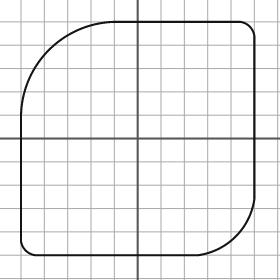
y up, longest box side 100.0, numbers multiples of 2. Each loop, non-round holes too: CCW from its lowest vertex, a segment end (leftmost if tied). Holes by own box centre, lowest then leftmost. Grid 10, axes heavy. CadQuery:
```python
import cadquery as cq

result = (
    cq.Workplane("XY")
    .moveTo(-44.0, -50.0)
    .lineTo(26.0, -50.0)
    .threePointArc((42.0, -42.0), (50.0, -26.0))
    .lineTo(50.0, 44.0)
    .threePointArc((48.0, 48.0), (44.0, 50.0))
    .lineTo(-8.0, 50.0)
    .threePointArc((-38.0, 38.0), (-50.0, 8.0))
    .lineTo(-50.0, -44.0)
    .threePointArc((-48.0, -48.0), (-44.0, -50.0))
    .close()
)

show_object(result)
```